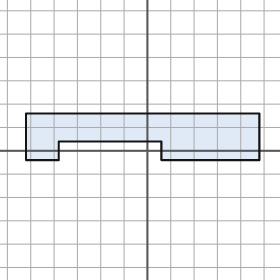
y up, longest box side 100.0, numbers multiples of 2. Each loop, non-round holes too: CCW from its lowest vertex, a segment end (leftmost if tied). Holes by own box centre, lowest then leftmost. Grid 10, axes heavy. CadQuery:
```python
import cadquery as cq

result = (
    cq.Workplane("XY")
    .moveTo(-52.0, -4.0)
    .lineTo(-38.0, -4.0)
    .lineTo(-38.0, 4.0)
    .lineTo(6.0, 4.0)
    .lineTo(6.0, -4.0)
    .lineTo(48.0, -4.0)
    .lineTo(48.0, 16.0)
    .lineTo(-52.0, 16.0)
    .close()
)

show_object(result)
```